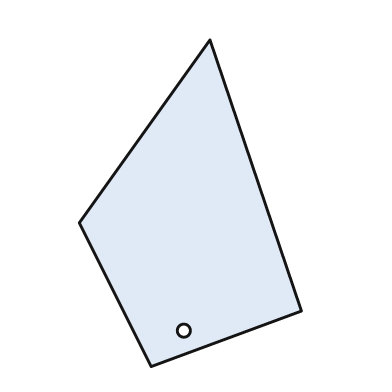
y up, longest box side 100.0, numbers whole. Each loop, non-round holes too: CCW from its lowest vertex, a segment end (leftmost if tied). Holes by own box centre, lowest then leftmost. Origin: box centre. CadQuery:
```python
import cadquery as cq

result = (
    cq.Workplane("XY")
    .moveTo(-12.0, -50.0)
    .lineTo(34.0, -33.0)
    .lineTo(6.0, 50.0)
    .lineTo(-34.0, -6.0)
    .close()
    .moveTo(-2.0, -39.0)
    .circle(2.0)
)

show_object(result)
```